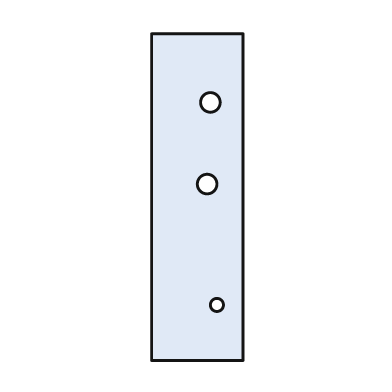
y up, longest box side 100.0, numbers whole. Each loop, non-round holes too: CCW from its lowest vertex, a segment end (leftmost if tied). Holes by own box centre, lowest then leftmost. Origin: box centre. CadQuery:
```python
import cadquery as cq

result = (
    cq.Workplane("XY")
    .moveTo(-14.0, -50.0)
    .lineTo(14.0, -50.0)
    .lineTo(14.0, 50.0)
    .lineTo(-14.0, 50.0)
    .close()
    .moveTo(6.0, -33.0)
    .circle(2.0)
    .moveTo(3.0, 4.0)
    .circle(3.0)
    .moveTo(4.0, 29.0)
    .circle(3.0)
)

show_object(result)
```